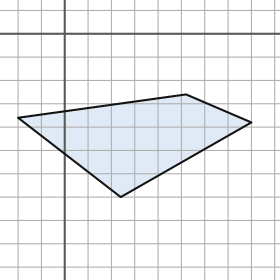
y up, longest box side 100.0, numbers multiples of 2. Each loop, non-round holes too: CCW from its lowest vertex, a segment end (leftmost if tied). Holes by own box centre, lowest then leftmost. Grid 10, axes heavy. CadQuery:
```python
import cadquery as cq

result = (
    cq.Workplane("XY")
    .moveTo(24.0, -70.0)
    .lineTo(80.0, -38.0)
    .lineTo(52.0, -26.0)
    .lineTo(-20.0, -36.0)
    .close()
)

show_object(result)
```